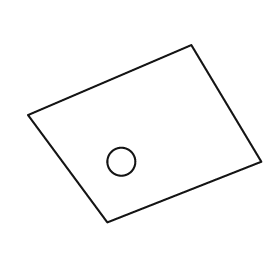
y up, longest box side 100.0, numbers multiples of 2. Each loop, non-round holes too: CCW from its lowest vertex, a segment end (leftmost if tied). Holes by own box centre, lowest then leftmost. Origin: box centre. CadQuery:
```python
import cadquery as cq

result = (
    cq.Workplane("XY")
    .moveTo(-16.0, -38.0)
    .lineTo(50.0, -12.0)
    .lineTo(20.0, 38.0)
    .lineTo(-50.0, 8.0)
    .close()
    .moveTo(-10.0, -12.0)
    .circle(6.0)
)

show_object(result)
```